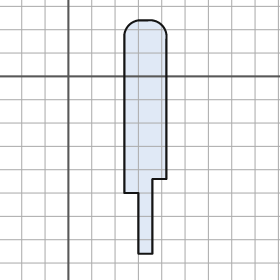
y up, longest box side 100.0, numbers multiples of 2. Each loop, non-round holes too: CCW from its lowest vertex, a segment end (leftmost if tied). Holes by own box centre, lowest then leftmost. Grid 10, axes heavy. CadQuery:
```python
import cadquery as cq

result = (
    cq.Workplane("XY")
    .moveTo(30.0, -76.0)
    .lineTo(36.0, -76.0)
    .lineTo(36.0, -44.0)
    .lineTo(42.0, -44.0)
    .lineTo(42.0, 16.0)
    .threePointArc((40.0, 22.0), (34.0, 24.0))
    .lineTo(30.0, 24.0)
    .threePointArc((26.0, 22.0), (24.0, 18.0))
    .lineTo(24.0, -50.0)
    .lineTo(30.0, -50.0)
    .close()
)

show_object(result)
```